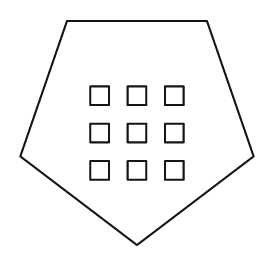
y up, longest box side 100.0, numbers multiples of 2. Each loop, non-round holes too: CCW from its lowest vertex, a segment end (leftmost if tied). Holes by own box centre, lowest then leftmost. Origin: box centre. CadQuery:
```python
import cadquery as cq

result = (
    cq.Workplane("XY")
    .moveTo(0.0, -48.0)
    .lineTo(50.0, -10.0)
    .lineTo(30.0, 48.0)
    .lineTo(-30.0, 48.0)
    .lineTo(-50.0, -10.0)
    .close()
    .moveTo(-20.0, -20.0)
    .lineTo(-12.0, -20.0)
    .lineTo(-12.0, -12.0)
    .lineTo(-20.0, -12.0)
    .close()
    .moveTo(-4.0, -20.0)
    .lineTo(4.0, -20.0)
    .lineTo(4.0, -12.0)
    .lineTo(-4.0, -12.0)
    .close()
    .moveTo(12.0, -20.0)
    .lineTo(20.0, -20.0)
    .lineTo(20.0, -12.0)
    .lineTo(12.0, -12.0)
    .close()
    .moveTo(-20.0, -4.0)
    .lineTo(-12.0, -4.0)
    .lineTo(-12.0, 4.0)
    .lineTo(-20.0, 4.0)
    .close()
    .moveTo(-4.0, -4.0)
    .lineTo(4.0, -4.0)
    .lineTo(4.0, 4.0)
    .lineTo(-4.0, 4.0)
    .close()
    .moveTo(12.0, -4.0)
    .lineTo(20.0, -4.0)
    .lineTo(20.0, 4.0)
    .lineTo(12.0, 4.0)
    .close()
    .moveTo(-20.0, 12.0)
    .lineTo(-12.0, 12.0)
    .lineTo(-12.0, 20.0)
    .lineTo(-20.0, 20.0)
    .close()
    .moveTo(-4.0, 12.0)
    .lineTo(4.0, 12.0)
    .lineTo(4.0, 20.0)
    .lineTo(-4.0, 20.0)
    .close()
    .moveTo(12.0, 12.0)
    .lineTo(20.0, 12.0)
    .lineTo(20.0, 20.0)
    .lineTo(12.0, 20.0)
    .close()
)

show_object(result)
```